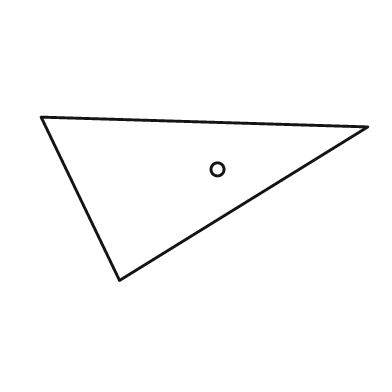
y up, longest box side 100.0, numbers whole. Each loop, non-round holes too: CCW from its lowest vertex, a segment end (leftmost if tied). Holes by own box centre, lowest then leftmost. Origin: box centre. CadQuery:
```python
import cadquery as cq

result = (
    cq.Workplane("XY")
    .moveTo(-26.0, -25.0)
    .lineTo(50.0, 22.0)
    .lineTo(-50.0, 25.0)
    .close()
    .moveTo(4.0, 9.0)
    .circle(2.0)
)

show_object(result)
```